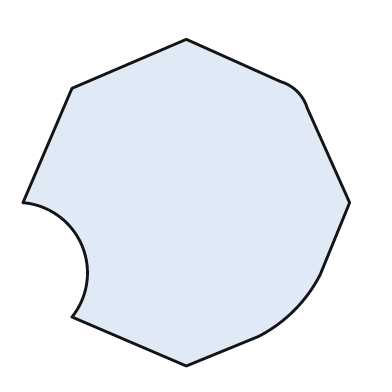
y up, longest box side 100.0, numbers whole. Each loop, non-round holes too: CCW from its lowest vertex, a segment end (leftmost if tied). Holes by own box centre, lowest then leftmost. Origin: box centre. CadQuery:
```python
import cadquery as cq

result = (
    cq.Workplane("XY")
    .moveTo(0.0, -50.0)
    .lineTo(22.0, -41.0)
    .threePointArc((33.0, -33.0), (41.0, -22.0))
    .lineTo(50.0, 0.0)
    .lineTo(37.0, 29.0)
    .threePointArc((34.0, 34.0), (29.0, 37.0))
    .lineTo(0.0, 50.0)
    .lineTo(-35.0, 35.0)
    .lineTo(-50.0, 0.0)
    .threePointArc((-32.0, -13.0), (-35.0, -35.0))
    .close()
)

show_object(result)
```